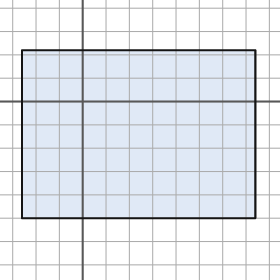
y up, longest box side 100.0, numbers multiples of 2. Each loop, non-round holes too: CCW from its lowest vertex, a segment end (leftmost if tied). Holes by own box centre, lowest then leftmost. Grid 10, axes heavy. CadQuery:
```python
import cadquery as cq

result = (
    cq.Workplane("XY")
    .moveTo(-26.0, -50.0)
    .lineTo(74.0, -50.0)
    .lineTo(74.0, 22.0)
    .lineTo(-26.0, 22.0)
    .close()
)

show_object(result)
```